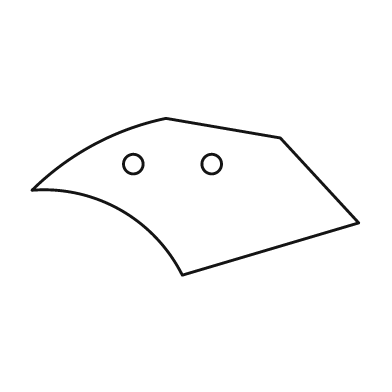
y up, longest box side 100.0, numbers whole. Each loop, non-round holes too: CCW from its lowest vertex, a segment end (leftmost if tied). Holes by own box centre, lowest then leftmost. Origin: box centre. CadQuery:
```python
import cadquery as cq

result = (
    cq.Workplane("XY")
    .moveTo(-4.0, -24.0)
    .lineTo(50.0, -8.0)
    .lineTo(26.0, 18.0)
    .lineTo(-9.0, 24.0)
    .threePointArc((-31.0, 16.0), (-50.0, 2.0))
    .threePointArc((-23.0, -4.0), (-4.0, -24.0))
    .close()
    .moveTo(-19.0, 10.0)
    .circle(3.0)
    .moveTo(5.0, 10.0)
    .circle(3.0)
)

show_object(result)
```